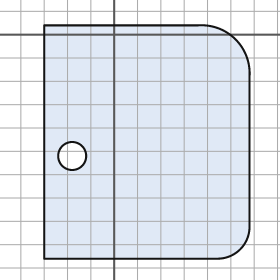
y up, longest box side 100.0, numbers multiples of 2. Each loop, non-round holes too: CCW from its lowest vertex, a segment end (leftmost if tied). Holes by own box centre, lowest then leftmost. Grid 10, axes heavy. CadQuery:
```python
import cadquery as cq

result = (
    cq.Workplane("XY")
    .moveTo(-30.0, -96.0)
    .lineTo(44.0, -96.0)
    .threePointArc((54.0, -92.0), (58.0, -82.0))
    .lineTo(58.0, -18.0)
    .threePointArc((52.0, -2.0), (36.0, 4.0))
    .lineTo(-30.0, 4.0)
    .close()
    .moveTo(-18.0, -52.0)
    .circle(6.0)
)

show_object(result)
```